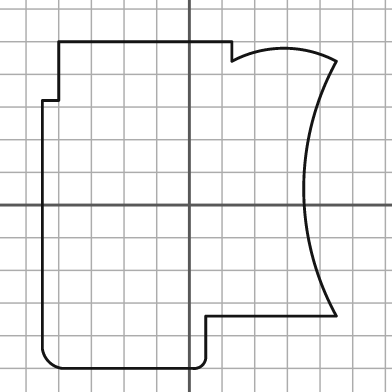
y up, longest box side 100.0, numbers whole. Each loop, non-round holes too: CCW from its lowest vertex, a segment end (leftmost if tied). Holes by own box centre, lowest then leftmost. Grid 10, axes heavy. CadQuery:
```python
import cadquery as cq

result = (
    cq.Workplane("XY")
    .moveTo(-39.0, -50.0)
    .lineTo(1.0, -50.0)
    .threePointArc((4.0, -49.0), (5.0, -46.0))
    .lineTo(5.0, -34.0)
    .lineTo(45.0, -34.0)
    .threePointArc((35.0, 5.0), (45.0, 44.0))
    .threePointArc((29.0, 48.0), (13.0, 44.0))
    .lineTo(13.0, 50.0)
    .lineTo(-40.0, 50.0)
    .lineTo(-40.0, 32.0)
    .lineTo(-45.0, 32.0)
    .lineTo(-45.0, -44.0)
    .threePointArc((-43.0, -48.0), (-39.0, -50.0))
    .close()
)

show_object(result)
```